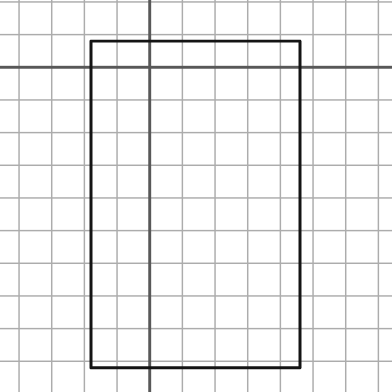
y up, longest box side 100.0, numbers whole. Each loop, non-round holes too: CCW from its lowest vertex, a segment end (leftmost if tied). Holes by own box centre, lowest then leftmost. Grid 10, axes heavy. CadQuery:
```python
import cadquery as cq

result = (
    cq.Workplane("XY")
    .moveTo(-18.0, -92.0)
    .lineTo(46.0, -92.0)
    .lineTo(46.0, 8.0)
    .lineTo(-18.0, 8.0)
    .close()
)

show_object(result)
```